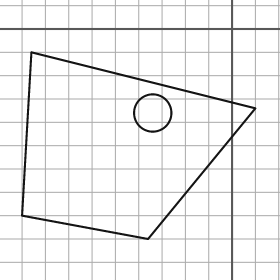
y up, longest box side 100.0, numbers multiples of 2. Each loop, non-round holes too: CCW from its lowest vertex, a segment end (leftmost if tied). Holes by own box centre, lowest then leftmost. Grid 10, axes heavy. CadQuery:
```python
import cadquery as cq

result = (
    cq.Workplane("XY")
    .moveTo(-36.0, -90.0)
    .lineTo(10.0, -34.0)
    .lineTo(-86.0, -10.0)
    .lineTo(-90.0, -80.0)
    .close()
    .moveTo(-34.0, -36.0)
    .circle(8.0)
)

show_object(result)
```